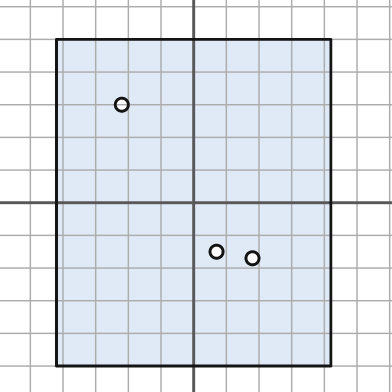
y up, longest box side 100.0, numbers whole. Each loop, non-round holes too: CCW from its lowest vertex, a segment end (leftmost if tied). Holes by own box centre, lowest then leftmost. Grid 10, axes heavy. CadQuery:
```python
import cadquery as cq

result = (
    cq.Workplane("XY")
    .moveTo(-42.0, -50.0)
    .lineTo(42.0, -50.0)
    .lineTo(42.0, 50.0)
    .lineTo(-42.0, 50.0)
    .close()
    .moveTo(18.0, -17.0)
    .circle(2.0)
    .moveTo(7.0, -15.0)
    .circle(2.0)
    .moveTo(-22.0, 30.0)
    .circle(2.0)
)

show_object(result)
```